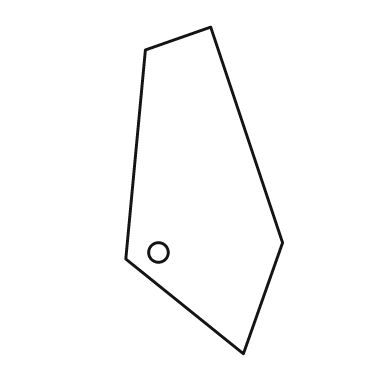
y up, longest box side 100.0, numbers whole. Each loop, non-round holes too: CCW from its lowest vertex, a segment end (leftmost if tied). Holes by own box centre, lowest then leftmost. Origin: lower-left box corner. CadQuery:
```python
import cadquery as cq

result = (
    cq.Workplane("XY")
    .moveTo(36.0, 0.0)
    .lineTo(48.0, 34.0)
    .lineTo(26.0, 100.0)
    .lineTo(6.0, 93.0)
    .lineTo(0.0, 29.0)
    .close()
    .moveTo(10.0, 31.0)
    .circle(3.0)
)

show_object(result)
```